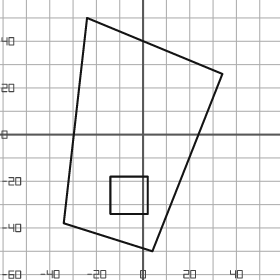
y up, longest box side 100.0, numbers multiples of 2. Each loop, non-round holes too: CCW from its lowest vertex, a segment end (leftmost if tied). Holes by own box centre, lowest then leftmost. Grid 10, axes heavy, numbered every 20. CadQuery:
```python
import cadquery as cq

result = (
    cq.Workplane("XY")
    .moveTo(4.0, -50.0)
    .lineTo(34.0, 26.0)
    .lineTo(-24.0, 50.0)
    .lineTo(-34.0, -38.0)
    .close()
    .moveTo(-14.0, -34.0)
    .lineTo(2.0, -34.0)
    .lineTo(2.0, -18.0)
    .lineTo(-14.0, -18.0)
    .close()
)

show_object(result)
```